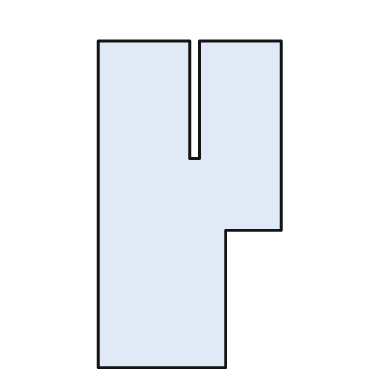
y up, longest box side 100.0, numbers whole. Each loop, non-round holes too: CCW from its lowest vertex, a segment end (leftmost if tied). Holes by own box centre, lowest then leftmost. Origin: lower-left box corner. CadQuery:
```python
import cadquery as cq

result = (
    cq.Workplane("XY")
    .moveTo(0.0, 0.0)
    .lineTo(39.0, 0.0)
    .lineTo(39.0, 42.0)
    .lineTo(56.0, 42.0)
    .lineTo(56.0, 100.0)
    .lineTo(31.0, 100.0)
    .lineTo(31.0, 64.0)
    .lineTo(28.0, 64.0)
    .lineTo(28.0, 100.0)
    .lineTo(0.0, 100.0)
    .close()
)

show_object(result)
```